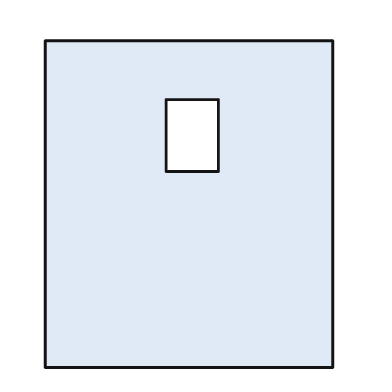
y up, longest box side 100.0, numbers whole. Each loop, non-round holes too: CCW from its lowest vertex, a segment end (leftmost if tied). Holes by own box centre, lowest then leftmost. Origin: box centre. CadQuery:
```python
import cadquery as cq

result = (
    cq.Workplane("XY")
    .moveTo(-44.0, -50.0)
    .lineTo(44.0, -50.0)
    .lineTo(44.0, 50.0)
    .lineTo(-44.0, 50.0)
    .close()
    .moveTo(-7.0, 10.0)
    .lineTo(9.0, 10.0)
    .lineTo(9.0, 32.0)
    .lineTo(-7.0, 32.0)
    .close()
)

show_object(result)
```